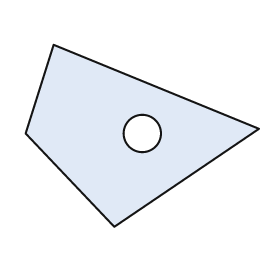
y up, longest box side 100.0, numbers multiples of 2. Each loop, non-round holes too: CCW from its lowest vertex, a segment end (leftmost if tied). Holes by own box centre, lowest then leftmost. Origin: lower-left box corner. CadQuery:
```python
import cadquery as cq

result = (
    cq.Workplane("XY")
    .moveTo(38.0, 0.0)
    .lineTo(100.0, 42.0)
    .lineTo(12.0, 78.0)
    .lineTo(0.0, 40.0)
    .close()
    .moveTo(50.0, 40.0)
    .circle(8.0)
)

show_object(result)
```